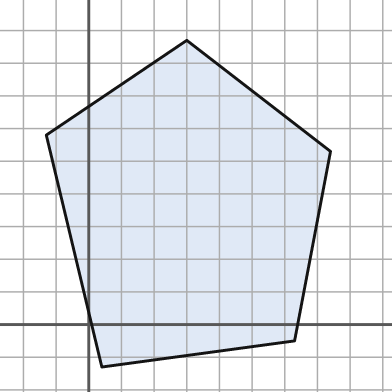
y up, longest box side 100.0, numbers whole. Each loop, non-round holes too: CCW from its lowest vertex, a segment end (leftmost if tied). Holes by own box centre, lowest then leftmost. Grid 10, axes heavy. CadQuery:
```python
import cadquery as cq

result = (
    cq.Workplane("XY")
    .moveTo(4.0, -13.0)
    .lineTo(63.0, -5.0)
    .lineTo(74.0, 53.0)
    .lineTo(30.0, 87.0)
    .lineTo(-13.0, 58.0)
    .close()
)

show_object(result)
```